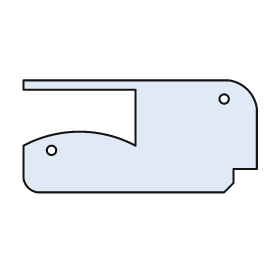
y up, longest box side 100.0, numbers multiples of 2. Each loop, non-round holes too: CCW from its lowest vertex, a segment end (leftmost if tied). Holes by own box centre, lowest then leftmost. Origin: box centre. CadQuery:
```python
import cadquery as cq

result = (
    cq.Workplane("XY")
    .moveTo(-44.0, -24.0)
    .lineTo(36.0, -24.0)
    .lineTo(40.0, -20.0)
    .lineTo(40.0, -14.0)
    .lineTo(50.0, -14.0)
    .lineTo(50.0, 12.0)
    .threePointArc((46.0, 20.0), (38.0, 24.0))
    .lineTo(-50.0, 24.0)
    .lineTo(-50.0, 20.0)
    .lineTo(-2.0, 20.0)
    .lineTo(-2.0, -4.0)
    .threePointArc((-26.0, 2.0), (-50.0, -4.0))
    .lineTo(-50.0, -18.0)
    .threePointArc((-48.0, -22.0), (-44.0, -24.0))
    .close()
    .moveTo(-38.0, -6.0)
    .circle(2.0)
    .moveTo(36.0, 16.0)
    .circle(2.0)
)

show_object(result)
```